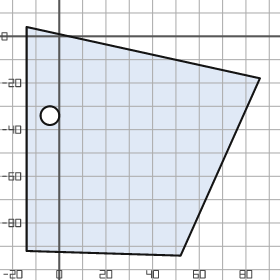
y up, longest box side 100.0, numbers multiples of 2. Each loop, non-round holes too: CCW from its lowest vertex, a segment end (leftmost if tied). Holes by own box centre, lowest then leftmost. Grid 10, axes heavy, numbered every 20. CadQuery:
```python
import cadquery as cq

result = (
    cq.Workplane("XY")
    .moveTo(52.0, -94.0)
    .lineTo(86.0, -18.0)
    .lineTo(-14.0, 4.0)
    .lineTo(-14.0, -92.0)
    .close()
    .moveTo(-4.0, -34.0)
    .circle(4.0)
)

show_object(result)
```